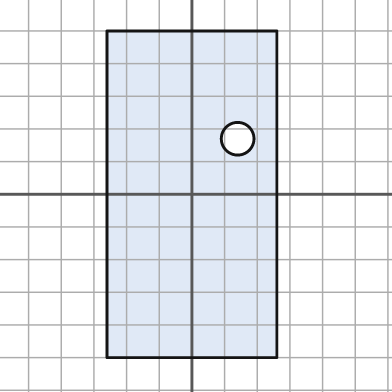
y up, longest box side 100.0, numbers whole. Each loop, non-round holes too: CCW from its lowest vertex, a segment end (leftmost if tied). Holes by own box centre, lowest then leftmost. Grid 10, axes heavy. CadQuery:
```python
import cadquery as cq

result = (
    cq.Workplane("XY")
    .moveTo(-26.0, -50.0)
    .lineTo(26.0, -50.0)
    .lineTo(26.0, 50.0)
    .lineTo(-26.0, 50.0)
    .close()
    .moveTo(14.0, 17.0)
    .circle(5.0)
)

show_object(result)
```